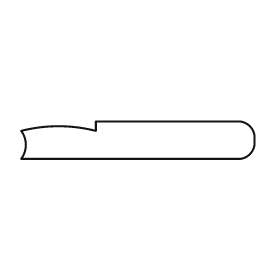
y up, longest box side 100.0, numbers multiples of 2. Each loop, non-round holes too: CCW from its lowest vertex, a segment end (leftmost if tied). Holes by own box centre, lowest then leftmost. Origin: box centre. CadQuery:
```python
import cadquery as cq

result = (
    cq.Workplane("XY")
    .moveTo(-50.0, -8.0)
    .lineTo(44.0, -8.0)
    .threePointArc((48.0, -6.0), (50.0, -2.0))
    .lineTo(50.0, 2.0)
    .threePointArc((48.0, 6.0), (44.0, 8.0))
    .lineTo(-18.0, 8.0)
    .lineTo(-18.0, 4.0)
    .threePointArc((-34.0, 6.0), (-50.0, 4.0))
    .threePointArc((-48.0, -2.0), (-50.0, -8.0))
    .close()
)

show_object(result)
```